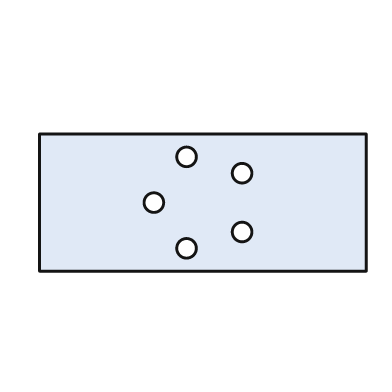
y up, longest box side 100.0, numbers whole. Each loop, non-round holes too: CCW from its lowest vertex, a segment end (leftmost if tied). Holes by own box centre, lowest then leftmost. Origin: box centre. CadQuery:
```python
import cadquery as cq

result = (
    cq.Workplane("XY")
    .moveTo(-50.0, -21.0)
    .lineTo(50.0, -21.0)
    .lineTo(50.0, 21.0)
    .lineTo(-50.0, 21.0)
    .close()
    .moveTo(-5.0, -14.0)
    .circle(3.0)
    .moveTo(12.0, -9.0)
    .circle(3.0)
    .moveTo(-15.0, 0.0)
    .circle(3.0)
    .moveTo(12.0, 9.0)
    .circle(3.0)
    .moveTo(-5.0, 14.0)
    .circle(3.0)
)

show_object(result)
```